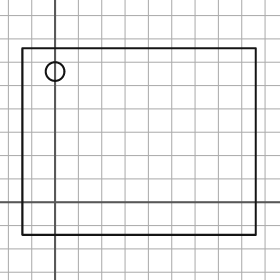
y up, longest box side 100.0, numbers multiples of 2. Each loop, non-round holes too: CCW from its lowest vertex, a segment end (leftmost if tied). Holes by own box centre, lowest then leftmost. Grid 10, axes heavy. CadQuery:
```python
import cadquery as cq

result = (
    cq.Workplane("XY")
    .moveTo(-14.0, -14.0)
    .lineTo(86.0, -14.0)
    .lineTo(86.0, 66.0)
    .lineTo(-14.0, 66.0)
    .close()
    .moveTo(0.0, 56.0)
    .circle(4.0)
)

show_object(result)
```